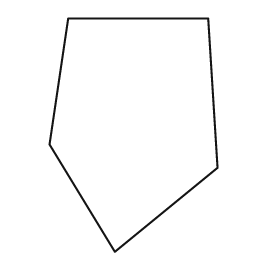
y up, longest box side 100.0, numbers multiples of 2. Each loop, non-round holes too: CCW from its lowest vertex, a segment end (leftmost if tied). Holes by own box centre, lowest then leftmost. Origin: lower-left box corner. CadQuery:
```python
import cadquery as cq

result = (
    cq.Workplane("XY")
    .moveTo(28.0, 0.0)
    .lineTo(72.0, 36.0)
    .lineTo(68.0, 100.0)
    .lineTo(8.0, 100.0)
    .lineTo(0.0, 46.0)
    .close()
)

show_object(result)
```